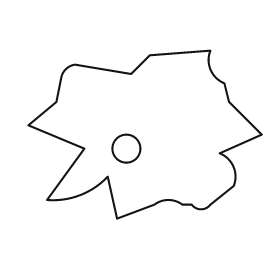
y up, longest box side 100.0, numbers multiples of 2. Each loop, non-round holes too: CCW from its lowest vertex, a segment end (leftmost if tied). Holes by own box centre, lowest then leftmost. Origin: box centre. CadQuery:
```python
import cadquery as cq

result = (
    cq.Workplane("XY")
    .moveTo(-12.0, -36.0)
    .lineTo(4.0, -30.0)
    .threePointArc((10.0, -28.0), (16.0, -30.0))
    .lineTo(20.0, -30.0)
    .threePointArc((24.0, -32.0), (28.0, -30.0))
    .lineTo(38.0, -22.0)
    .threePointArc((38.0, -14.0), (32.0, -8.0))
    .lineTo(50.0, 0.0)
    .lineTo(36.0, 14.0)
    .lineTo(34.0, 22.0)
    .threePointArc((28.0, 28.0), (28.0, 36.0))
    .lineTo(2.0, 34.0)
    .lineTo(-6.0, 26.0)
    .lineTo(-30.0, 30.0)
    .threePointArc((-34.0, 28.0), (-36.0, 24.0))
    .lineTo(-38.0, 14.0)
    .lineTo(-50.0, 4.0)
    .lineTo(-26.0, -6.0)
    .lineTo(-42.0, -28.0)
    .threePointArc((-28.0, -26.0), (-16.0, -18.0))
    .close()
    .moveTo(-8.0, -6.0)
    .circle(6.0)
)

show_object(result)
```